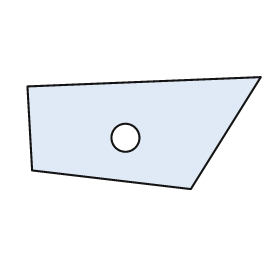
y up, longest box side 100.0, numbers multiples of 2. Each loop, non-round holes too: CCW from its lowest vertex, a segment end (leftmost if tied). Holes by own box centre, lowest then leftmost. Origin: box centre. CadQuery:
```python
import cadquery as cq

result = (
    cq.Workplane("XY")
    .moveTo(20.0, -24.0)
    .lineTo(50.0, 24.0)
    .lineTo(-50.0, 20.0)
    .lineTo(-48.0, -16.0)
    .close()
    .moveTo(-8.0, -2.0)
    .circle(6.0)
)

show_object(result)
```